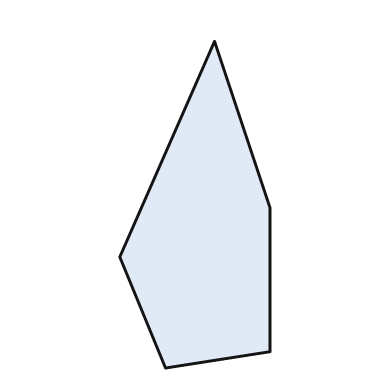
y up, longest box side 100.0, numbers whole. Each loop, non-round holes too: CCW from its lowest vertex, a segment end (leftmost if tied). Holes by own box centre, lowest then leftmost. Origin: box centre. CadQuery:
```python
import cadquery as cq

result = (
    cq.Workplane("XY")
    .moveTo(-9.0, -50.0)
    .lineTo(23.0, -45.0)
    .lineTo(23.0, -1.0)
    .lineTo(6.0, 50.0)
    .lineTo(-23.0, -16.0)
    .close()
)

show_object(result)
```